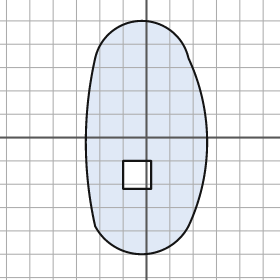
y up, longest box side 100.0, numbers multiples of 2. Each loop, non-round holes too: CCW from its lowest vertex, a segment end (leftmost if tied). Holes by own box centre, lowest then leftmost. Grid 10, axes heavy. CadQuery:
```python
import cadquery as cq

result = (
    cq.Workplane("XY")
    .moveTo(-22.0, -38.0)
    .threePointArc((-2.0, -50.0), (18.0, -38.0))
    .threePointArc((26.0, -2.0), (18.0, 34.0))
    .threePointArc((-2.0, 50.0), (-22.0, 34.0))
    .threePointArc((-26.0, -2.0), (-22.0, -38.0))
    .close()
    .moveTo(-10.0, -22.0)
    .lineTo(2.0, -22.0)
    .lineTo(2.0, -10.0)
    .lineTo(-10.0, -10.0)
    .close()
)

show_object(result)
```